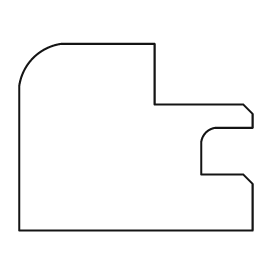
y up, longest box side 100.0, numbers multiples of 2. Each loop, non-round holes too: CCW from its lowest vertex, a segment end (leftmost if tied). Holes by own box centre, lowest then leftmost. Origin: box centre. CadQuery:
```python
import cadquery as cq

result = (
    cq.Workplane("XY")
    .moveTo(-50.0, -40.0)
    .lineTo(50.0, -40.0)
    .lineTo(50.0, -20.0)
    .lineTo(46.0, -16.0)
    .lineTo(28.0, -16.0)
    .lineTo(28.0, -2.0)
    .threePointArc((30.0, 2.0), (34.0, 4.0))
    .lineTo(50.0, 4.0)
    .lineTo(50.0, 10.0)
    .lineTo(46.0, 14.0)
    .lineTo(8.0, 14.0)
    .lineTo(8.0, 40.0)
    .lineTo(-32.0, 40.0)
    .threePointArc((-44.0, 34.0), (-50.0, 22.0))
    .close()
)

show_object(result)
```